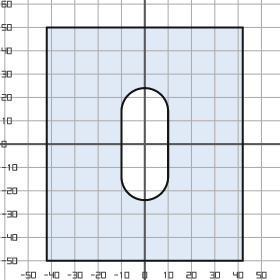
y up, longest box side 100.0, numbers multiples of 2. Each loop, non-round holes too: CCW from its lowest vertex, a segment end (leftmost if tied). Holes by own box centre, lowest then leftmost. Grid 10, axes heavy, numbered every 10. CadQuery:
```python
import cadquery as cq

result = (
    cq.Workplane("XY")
    .moveTo(-42.0, -50.0)
    .lineTo(42.0, -50.0)
    .lineTo(42.0, 50.0)
    .lineTo(-42.0, 50.0)
    .close()
    .moveTo(-10.0, -14.0)
    .threePointArc((0.0, -24.0), (10.0, -14.0))
    .lineTo(10.0, 14.0)
    .threePointArc((0.0, 24.0), (-10.0, 14.0))
    .close()
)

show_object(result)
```